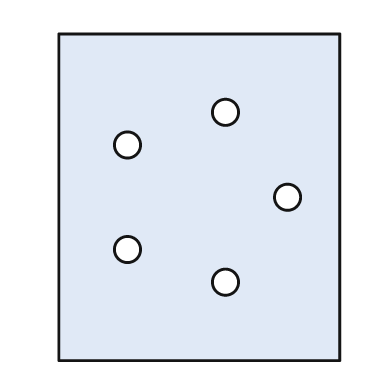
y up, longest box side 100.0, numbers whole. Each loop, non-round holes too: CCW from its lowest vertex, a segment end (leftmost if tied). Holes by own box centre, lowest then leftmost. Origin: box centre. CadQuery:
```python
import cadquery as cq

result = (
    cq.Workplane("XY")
    .moveTo(-43.0, -50.0)
    .lineTo(43.0, -50.0)
    .lineTo(43.0, 50.0)
    .lineTo(-43.0, 50.0)
    .close()
    .moveTo(8.0, -26.0)
    .circle(4.0)
    .moveTo(-22.0, -16.0)
    .circle(4.0)
    .moveTo(27.0, 0.0)
    .circle(4.0)
    .moveTo(-22.0, 16.0)
    .circle(4.0)
    .moveTo(8.0, 26.0)
    .circle(4.0)
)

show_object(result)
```